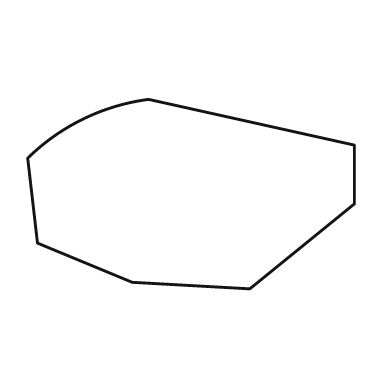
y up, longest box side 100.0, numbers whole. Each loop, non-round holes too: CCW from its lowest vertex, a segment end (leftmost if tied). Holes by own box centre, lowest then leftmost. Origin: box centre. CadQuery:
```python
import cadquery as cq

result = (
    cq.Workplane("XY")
    .moveTo(18.0, -29.0)
    .lineTo(50.0, -3.0)
    .lineTo(50.0, 15.0)
    .lineTo(-13.0, 29.0)
    .threePointArc((-33.0, 23.0), (-50.0, 11.0))
    .lineTo(-47.0, -15.0)
    .lineTo(-18.0, -27.0)
    .close()
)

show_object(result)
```